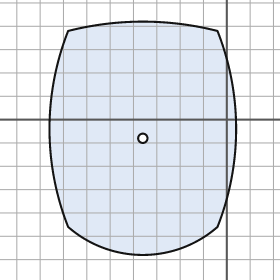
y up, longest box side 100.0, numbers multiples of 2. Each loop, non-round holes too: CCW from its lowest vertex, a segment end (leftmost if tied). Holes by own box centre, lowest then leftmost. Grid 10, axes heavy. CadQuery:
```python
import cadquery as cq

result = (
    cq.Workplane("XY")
    .moveTo(-68.0, -46.0)
    .threePointArc((-36.0, -58.0), (-4.0, -46.0))
    .threePointArc((4.0, -4.0), (-4.0, 38.0))
    .threePointArc((-36.0, 42.0), (-68.0, 38.0))
    .threePointArc((-76.0, -4.0), (-68.0, -46.0))
    .close()
    .moveTo(-36.0, -8.0)
    .circle(2.0)
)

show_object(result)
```